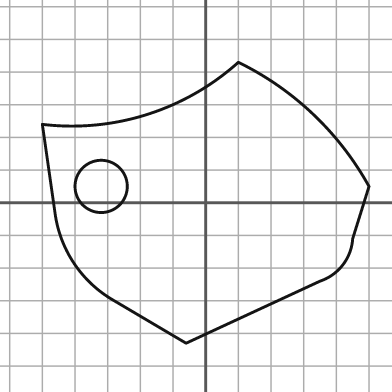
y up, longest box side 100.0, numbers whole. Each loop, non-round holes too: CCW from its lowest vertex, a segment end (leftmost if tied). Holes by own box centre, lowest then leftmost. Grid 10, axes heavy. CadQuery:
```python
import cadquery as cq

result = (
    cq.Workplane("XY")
    .moveTo(-6.0, -43.0)
    .lineTo(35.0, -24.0)
    .threePointArc((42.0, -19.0), (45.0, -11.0))
    .lineTo(50.0, 5.0)
    .threePointArc((33.0, 27.0), (10.0, 43.0))
    .threePointArc((-18.0, 27.0), (-50.0, 24.0))
    .lineTo(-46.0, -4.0)
    .threePointArc((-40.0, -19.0), (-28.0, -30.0))
    .close()
    .moveTo(-32.0, 5.0)
    .circle(8.0)
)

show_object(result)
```